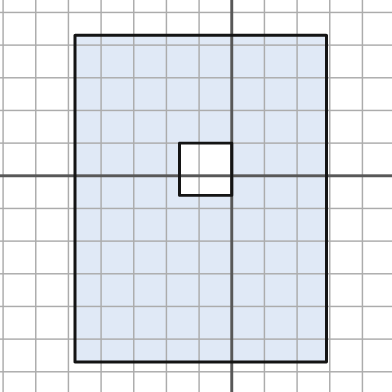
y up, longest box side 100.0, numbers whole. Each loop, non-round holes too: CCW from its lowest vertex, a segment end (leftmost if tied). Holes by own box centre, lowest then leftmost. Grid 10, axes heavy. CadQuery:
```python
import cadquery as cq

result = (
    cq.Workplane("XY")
    .moveTo(-48.0, -57.0)
    .lineTo(29.0, -57.0)
    .lineTo(29.0, 43.0)
    .lineTo(-48.0, 43.0)
    .close()
    .moveTo(-16.0, -6.0)
    .lineTo(0.0, -6.0)
    .lineTo(0.0, 10.0)
    .lineTo(-16.0, 10.0)
    .close()
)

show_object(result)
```